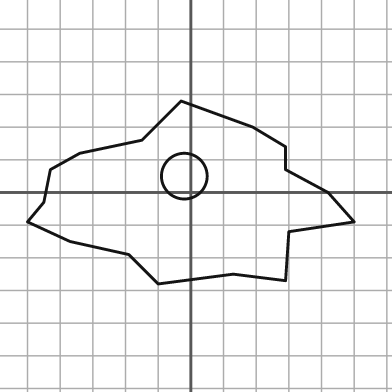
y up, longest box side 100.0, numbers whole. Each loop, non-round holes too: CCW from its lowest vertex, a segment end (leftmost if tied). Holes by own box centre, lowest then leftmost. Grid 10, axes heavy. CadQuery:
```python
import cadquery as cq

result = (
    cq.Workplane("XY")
    .moveTo(-10.0, -28.0)
    .lineTo(13.0, -25.0)
    .lineTo(29.0, -27.0)
    .lineTo(30.0, -12.0)
    .lineTo(50.0, -9.0)
    .lineTo(42.0, 0.0)
    .lineTo(29.0, 7.0)
    .lineTo(29.0, 14.0)
    .lineTo(19.0, 20.0)
    .lineTo(-3.0, 28.0)
    .lineTo(-15.0, 16.0)
    .lineTo(-34.0, 12.0)
    .lineTo(-43.0, 7.0)
    .lineTo(-45.0, -3.0)
    .lineTo(-50.0, -9.0)
    .lineTo(-37.0, -15.0)
    .lineTo(-19.0, -19.0)
    .close()
    .moveTo(-2.0, 5.0)
    .circle(7.0)
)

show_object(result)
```